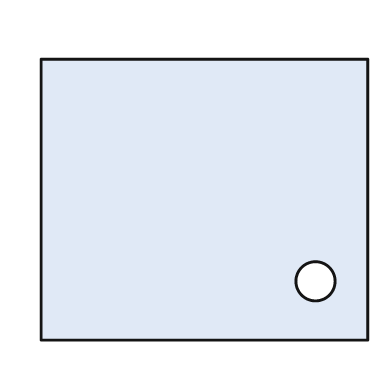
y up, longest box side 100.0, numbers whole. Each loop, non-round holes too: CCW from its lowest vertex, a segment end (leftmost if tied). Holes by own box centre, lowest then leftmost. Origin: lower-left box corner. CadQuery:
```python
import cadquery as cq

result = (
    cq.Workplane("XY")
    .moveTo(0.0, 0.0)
    .lineTo(100.0, 0.0)
    .lineTo(100.0, 86.0)
    .lineTo(0.0, 86.0)
    .close()
    .moveTo(84.0, 18.0)
    .circle(6.0)
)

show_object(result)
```